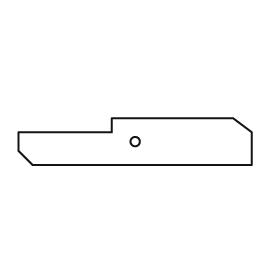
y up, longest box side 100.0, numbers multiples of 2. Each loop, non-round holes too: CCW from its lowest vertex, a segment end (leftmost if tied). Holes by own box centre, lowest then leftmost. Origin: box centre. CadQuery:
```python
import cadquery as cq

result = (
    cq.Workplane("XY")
    .moveTo(-44.0, -10.0)
    .lineTo(50.0, -10.0)
    .lineTo(50.0, 4.0)
    .lineTo(42.0, 10.0)
    .lineTo(-10.0, 10.0)
    .lineTo(-10.0, 4.0)
    .lineTo(-50.0, 4.0)
    .lineTo(-50.0, -4.0)
    .close()
    .moveTo(0.0, 0.0)
    .circle(2.0)
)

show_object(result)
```